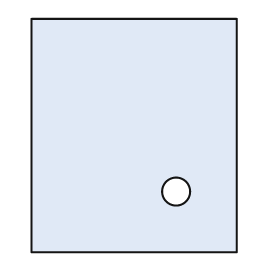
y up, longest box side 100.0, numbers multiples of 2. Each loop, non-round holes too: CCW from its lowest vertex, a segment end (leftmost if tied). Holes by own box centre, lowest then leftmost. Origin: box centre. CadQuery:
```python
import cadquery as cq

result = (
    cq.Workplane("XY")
    .moveTo(-44.0, -50.0)
    .lineTo(44.0, -50.0)
    .lineTo(44.0, 50.0)
    .lineTo(-44.0, 50.0)
    .close()
    .moveTo(18.0, -24.0)
    .circle(6.0)
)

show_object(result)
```